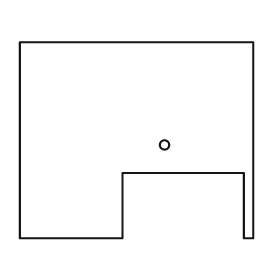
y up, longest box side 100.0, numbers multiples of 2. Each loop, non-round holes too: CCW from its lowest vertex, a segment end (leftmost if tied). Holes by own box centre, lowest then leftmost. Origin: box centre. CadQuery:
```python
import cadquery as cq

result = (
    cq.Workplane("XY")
    .moveTo(-50.0, -42.0)
    .lineTo(-6.0, -42.0)
    .lineTo(-6.0, -14.0)
    .lineTo(46.0, -14.0)
    .lineTo(46.0, -42.0)
    .lineTo(50.0, -42.0)
    .lineTo(50.0, 42.0)
    .lineTo(-50.0, 42.0)
    .close()
    .moveTo(12.0, -2.0)
    .circle(2.0)
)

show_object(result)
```